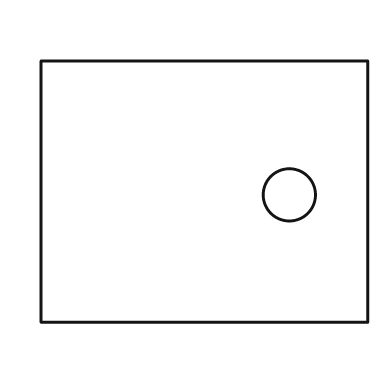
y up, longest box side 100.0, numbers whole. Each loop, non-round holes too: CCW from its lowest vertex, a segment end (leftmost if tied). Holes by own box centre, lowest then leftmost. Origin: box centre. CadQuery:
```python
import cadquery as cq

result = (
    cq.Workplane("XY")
    .moveTo(-50.0, -40.0)
    .lineTo(50.0, -40.0)
    .lineTo(50.0, 40.0)
    .lineTo(-50.0, 40.0)
    .close()
    .moveTo(26.0, -1.0)
    .circle(8.0)
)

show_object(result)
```